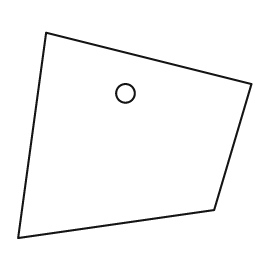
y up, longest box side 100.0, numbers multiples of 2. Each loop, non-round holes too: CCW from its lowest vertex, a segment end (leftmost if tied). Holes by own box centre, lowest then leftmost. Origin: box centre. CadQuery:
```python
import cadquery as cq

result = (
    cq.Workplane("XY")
    .moveTo(-50.0, -44.0)
    .lineTo(34.0, -32.0)
    .lineTo(50.0, 22.0)
    .lineTo(-38.0, 44.0)
    .close()
    .moveTo(-4.0, 18.0)
    .circle(4.0)
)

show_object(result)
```